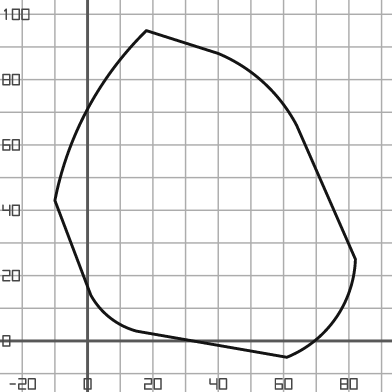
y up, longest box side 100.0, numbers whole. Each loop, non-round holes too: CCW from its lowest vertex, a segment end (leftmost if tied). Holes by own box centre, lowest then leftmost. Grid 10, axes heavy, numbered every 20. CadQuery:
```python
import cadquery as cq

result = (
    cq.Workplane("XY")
    .moveTo(61.0, -5.0)
    .threePointArc((76.0, 7.0), (82.0, 25.0))
    .lineTo(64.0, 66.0)
    .threePointArc((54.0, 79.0), (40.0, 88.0))
    .lineTo(18.0, 95.0)
    .threePointArc((0.0, 71.0), (-10.0, 43.0))
    .lineTo(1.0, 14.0)
    .threePointArc((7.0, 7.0), (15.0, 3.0))
    .close()
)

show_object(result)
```